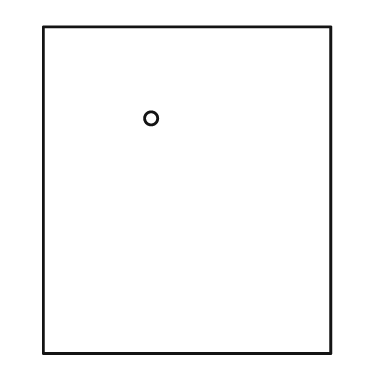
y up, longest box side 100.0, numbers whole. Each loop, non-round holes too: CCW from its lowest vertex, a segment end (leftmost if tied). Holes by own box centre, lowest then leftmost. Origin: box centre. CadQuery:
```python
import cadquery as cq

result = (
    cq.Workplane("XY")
    .moveTo(-44.0, -50.0)
    .lineTo(44.0, -50.0)
    .lineTo(44.0, 50.0)
    .lineTo(-44.0, 50.0)
    .close()
    .moveTo(-11.0, 22.0)
    .circle(2.0)
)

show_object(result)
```